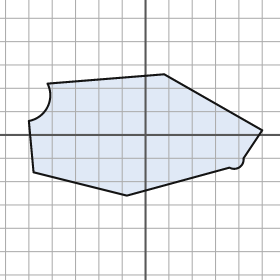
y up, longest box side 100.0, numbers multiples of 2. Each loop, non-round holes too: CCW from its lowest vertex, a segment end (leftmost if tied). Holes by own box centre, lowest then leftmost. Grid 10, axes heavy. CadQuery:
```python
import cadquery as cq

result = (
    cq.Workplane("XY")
    .moveTo(-8.0, -26.0)
    .lineTo(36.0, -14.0)
    .threePointArc((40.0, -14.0), (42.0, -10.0))
    .lineTo(50.0, 2.0)
    .lineTo(8.0, 26.0)
    .lineTo(-42.0, 22.0)
    .threePointArc((-42.0, 12.0), (-50.0, 6.0))
    .lineTo(-48.0, -16.0)
    .close()
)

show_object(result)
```